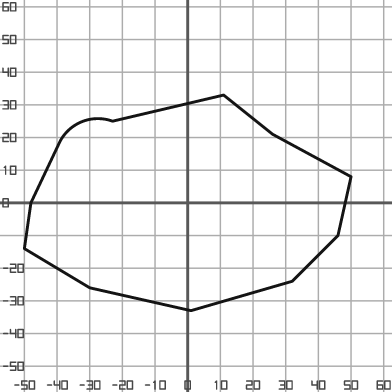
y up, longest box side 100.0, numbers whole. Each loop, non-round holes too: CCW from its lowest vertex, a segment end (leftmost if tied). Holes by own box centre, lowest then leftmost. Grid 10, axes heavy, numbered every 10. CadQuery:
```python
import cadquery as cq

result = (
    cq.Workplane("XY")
    .moveTo(1.0, -33.0)
    .lineTo(32.0, -24.0)
    .lineTo(46.0, -10.0)
    .lineTo(50.0, 8.0)
    .lineTo(26.0, 21.0)
    .lineTo(11.0, 33.0)
    .lineTo(-23.0, 25.0)
    .threePointArc((-32.0, 25.0), (-39.0, 19.0))
    .lineTo(-48.0, 0.0)
    .lineTo(-50.0, -14.0)
    .lineTo(-30.0, -26.0)
    .close()
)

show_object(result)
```